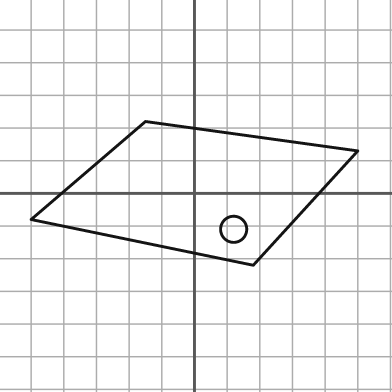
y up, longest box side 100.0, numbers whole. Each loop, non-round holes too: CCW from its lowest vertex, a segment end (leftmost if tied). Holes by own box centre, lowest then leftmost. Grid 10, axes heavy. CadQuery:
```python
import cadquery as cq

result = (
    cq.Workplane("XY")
    .moveTo(18.0, -22.0)
    .lineTo(50.0, 13.0)
    .lineTo(-15.0, 22.0)
    .lineTo(-50.0, -8.0)
    .close()
    .moveTo(12.0, -11.0)
    .circle(4.0)
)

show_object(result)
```